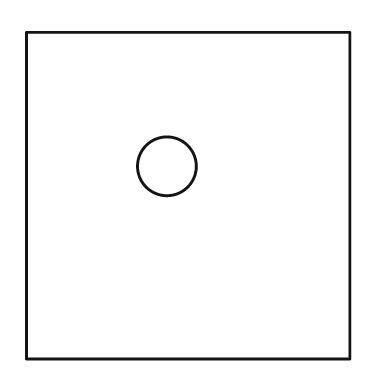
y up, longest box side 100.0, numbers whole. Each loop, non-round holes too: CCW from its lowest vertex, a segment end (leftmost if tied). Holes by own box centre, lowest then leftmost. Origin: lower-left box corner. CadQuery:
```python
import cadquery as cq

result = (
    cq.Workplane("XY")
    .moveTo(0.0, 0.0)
    .lineTo(99.0, 0.0)
    .lineTo(99.0, 100.0)
    .lineTo(0.0, 100.0)
    .close()
    .moveTo(43.0, 59.0)
    .circle(9.0)
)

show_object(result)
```